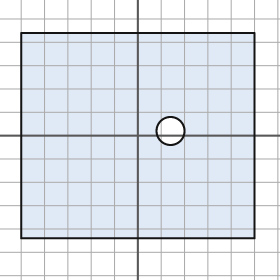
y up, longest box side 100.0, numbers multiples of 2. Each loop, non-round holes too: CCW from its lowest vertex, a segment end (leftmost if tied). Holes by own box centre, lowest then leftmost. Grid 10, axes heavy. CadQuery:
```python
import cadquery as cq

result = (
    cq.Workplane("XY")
    .moveTo(-50.0, -44.0)
    .lineTo(50.0, -44.0)
    .lineTo(50.0, 44.0)
    .lineTo(-50.0, 44.0)
    .close()
    .moveTo(14.0, 2.0)
    .circle(6.0)
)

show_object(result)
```